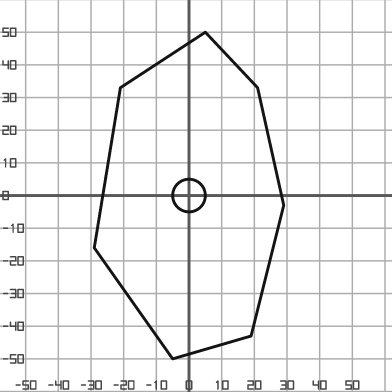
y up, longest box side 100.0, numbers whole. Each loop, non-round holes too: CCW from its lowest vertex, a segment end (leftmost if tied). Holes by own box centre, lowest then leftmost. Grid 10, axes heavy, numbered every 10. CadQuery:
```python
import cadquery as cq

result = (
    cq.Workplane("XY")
    .moveTo(-5.0, -50.0)
    .lineTo(19.0, -43.0)
    .lineTo(29.0, -3.0)
    .lineTo(21.0, 33.0)
    .lineTo(5.0, 50.0)
    .lineTo(-21.0, 33.0)
    .lineTo(-29.0, -16.0)
    .close()
    .moveTo(0.0, 0.0)
    .circle(5.0)
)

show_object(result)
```